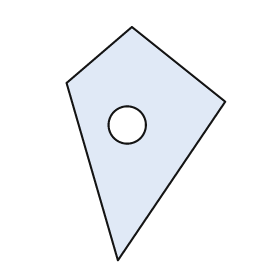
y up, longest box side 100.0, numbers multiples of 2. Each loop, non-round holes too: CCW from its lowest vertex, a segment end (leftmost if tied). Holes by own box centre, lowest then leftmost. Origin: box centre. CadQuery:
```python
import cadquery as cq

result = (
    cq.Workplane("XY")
    .moveTo(-12.0, -50.0)
    .lineTo(34.0, 18.0)
    .lineTo(-6.0, 50.0)
    .lineTo(-34.0, 26.0)
    .close()
    .moveTo(-8.0, 8.0)
    .circle(8.0)
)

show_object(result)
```